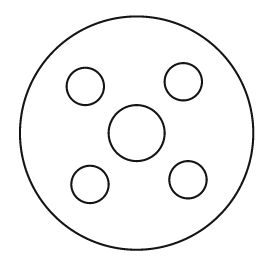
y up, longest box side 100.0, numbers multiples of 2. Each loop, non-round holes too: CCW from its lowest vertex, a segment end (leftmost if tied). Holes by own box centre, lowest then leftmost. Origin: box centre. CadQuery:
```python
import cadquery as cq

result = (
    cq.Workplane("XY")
    .moveTo(0.0, 0.0)
    .circle(50.0)
    .moveTo(-20.0, -22.0)
    .circle(8.0)
    .moveTo(22.0, -20.0)
    .circle(8.0)
    .moveTo(0.0, 0.0)
    .circle(12.0)
    .moveTo(-22.0, 20.0)
    .circle(8.0)
    .moveTo(20.0, 22.0)
    .circle(8.0)
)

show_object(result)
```